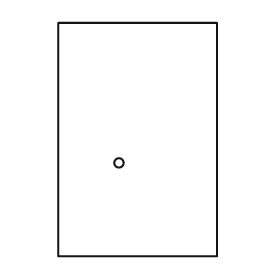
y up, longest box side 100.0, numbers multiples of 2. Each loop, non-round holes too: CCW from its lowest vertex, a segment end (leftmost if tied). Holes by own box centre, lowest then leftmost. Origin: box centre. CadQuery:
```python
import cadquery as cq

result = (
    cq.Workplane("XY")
    .moveTo(-34.0, -50.0)
    .lineTo(34.0, -50.0)
    .lineTo(34.0, 50.0)
    .lineTo(-34.0, 50.0)
    .close()
    .moveTo(-8.0, -10.0)
    .circle(2.0)
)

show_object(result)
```